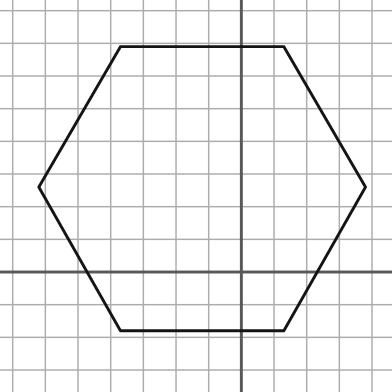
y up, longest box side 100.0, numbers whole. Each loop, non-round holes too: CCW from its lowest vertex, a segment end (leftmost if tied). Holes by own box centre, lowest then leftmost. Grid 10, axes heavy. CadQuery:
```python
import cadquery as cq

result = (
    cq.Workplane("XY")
    .moveTo(-37.0, -18.0)
    .lineTo(13.0, -18.0)
    .lineTo(38.0, 26.0)
    .lineTo(13.0, 69.0)
    .lineTo(-37.0, 69.0)
    .lineTo(-62.0, 26.0)
    .close()
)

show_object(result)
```